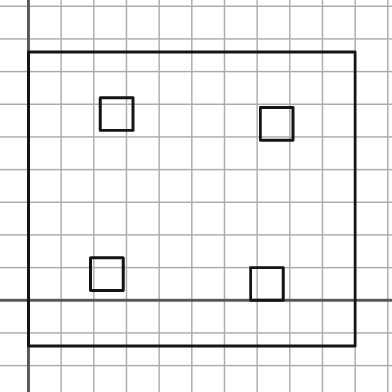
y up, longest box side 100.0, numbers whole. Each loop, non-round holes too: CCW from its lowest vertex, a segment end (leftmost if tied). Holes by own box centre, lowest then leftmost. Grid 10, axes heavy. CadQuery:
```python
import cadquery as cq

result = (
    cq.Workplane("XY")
    .moveTo(0.0, -14.0)
    .lineTo(100.0, -14.0)
    .lineTo(100.0, 76.0)
    .lineTo(0.0, 76.0)
    .close()
    .moveTo(68.0, 0.0)
    .lineTo(78.0, 0.0)
    .lineTo(78.0, 10.0)
    .lineTo(68.0, 10.0)
    .close()
    .moveTo(19.0, 3.0)
    .lineTo(29.0, 3.0)
    .lineTo(29.0, 13.0)
    .lineTo(19.0, 13.0)
    .close()
    .moveTo(71.0, 49.0)
    .lineTo(81.0, 49.0)
    .lineTo(81.0, 59.0)
    .lineTo(71.0, 59.0)
    .close()
    .moveTo(22.0, 52.0)
    .lineTo(32.0, 52.0)
    .lineTo(32.0, 62.0)
    .lineTo(22.0, 62.0)
    .close()
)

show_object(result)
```